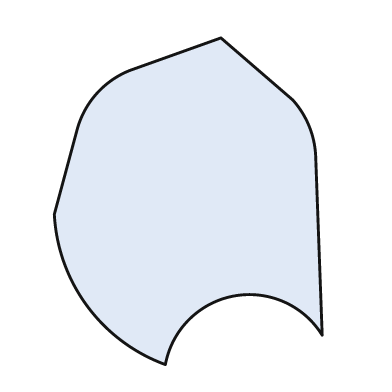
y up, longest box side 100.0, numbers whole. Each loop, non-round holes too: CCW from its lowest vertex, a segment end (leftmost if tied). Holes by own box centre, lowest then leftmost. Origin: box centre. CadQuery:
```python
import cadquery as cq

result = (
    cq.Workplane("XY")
    .moveTo(-7.0, -50.0)
    .threePointArc((14.0, -29.0), (41.0, -41.0))
    .lineTo(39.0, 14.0)
    .threePointArc((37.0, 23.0), (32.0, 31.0))
    .lineTo(10.0, 50.0)
    .lineTo(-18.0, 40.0)
    .threePointArc((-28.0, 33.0), (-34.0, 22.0))
    .lineTo(-41.0, -4.0)
    .threePointArc((-31.0, -32.0), (-7.0, -50.0))
    .close()
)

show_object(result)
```